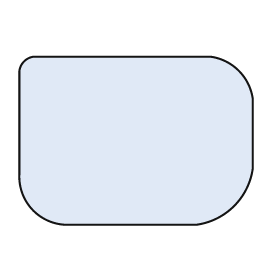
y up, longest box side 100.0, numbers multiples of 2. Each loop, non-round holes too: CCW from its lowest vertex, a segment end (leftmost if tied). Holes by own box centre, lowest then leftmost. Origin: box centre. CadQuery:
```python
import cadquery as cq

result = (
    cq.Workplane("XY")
    .moveTo(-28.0, -36.0)
    .lineTo(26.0, -36.0)
    .threePointArc((42.0, -28.0), (50.0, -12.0))
    .lineTo(50.0, 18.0)
    .threePointArc((44.0, 30.0), (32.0, 36.0))
    .lineTo(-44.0, 36.0)
    .threePointArc((-48.0, 34.0), (-50.0, 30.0))
    .lineTo(-50.0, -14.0)
    .threePointArc((-44.0, -30.0), (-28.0, -36.0))
    .close()
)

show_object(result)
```